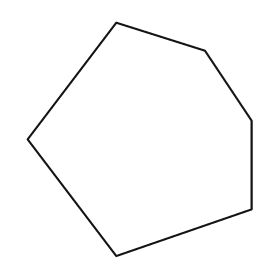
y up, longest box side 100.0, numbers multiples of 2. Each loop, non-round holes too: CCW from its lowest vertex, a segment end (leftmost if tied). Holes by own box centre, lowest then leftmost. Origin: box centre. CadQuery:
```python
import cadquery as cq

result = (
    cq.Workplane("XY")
    .moveTo(-10.0, -50.0)
    .lineTo(48.0, -30.0)
    .lineTo(48.0, 8.0)
    .lineTo(28.0, 38.0)
    .lineTo(-10.0, 50.0)
    .lineTo(-48.0, 0.0)
    .close()
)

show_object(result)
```